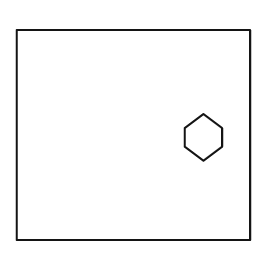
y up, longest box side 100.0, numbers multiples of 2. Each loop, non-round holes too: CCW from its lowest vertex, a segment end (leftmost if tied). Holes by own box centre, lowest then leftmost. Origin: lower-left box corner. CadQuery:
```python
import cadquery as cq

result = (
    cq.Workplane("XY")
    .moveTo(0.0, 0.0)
    .lineTo(100.0, 0.0)
    .lineTo(100.0, 90.0)
    .lineTo(0.0, 90.0)
    .close()
    .moveTo(80.0, 34.0)
    .lineTo(88.0, 40.0)
    .lineTo(88.0, 48.0)
    .lineTo(80.0, 54.0)
    .lineTo(72.0, 48.0)
    .lineTo(72.0, 40.0)
    .close()
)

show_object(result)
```